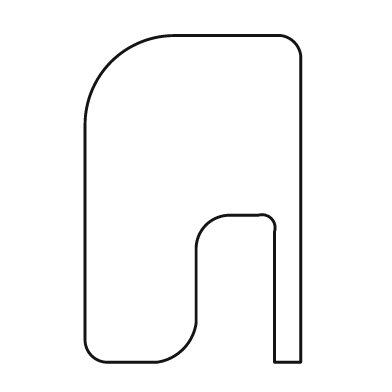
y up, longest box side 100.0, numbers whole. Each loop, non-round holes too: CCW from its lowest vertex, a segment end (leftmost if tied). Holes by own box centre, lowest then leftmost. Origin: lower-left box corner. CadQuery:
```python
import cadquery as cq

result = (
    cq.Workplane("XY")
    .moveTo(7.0, 0.0)
    .lineTo(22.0, 0.0)
    .threePointArc((30.0, 4.0), (34.0, 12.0))
    .lineTo(34.0, 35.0)
    .threePointArc((37.0, 42.0), (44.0, 45.0))
    .lineTo(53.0, 45.0)
    .threePointArc((57.0, 44.0), (58.0, 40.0))
    .lineTo(58.0, 0.0)
    .lineTo(66.0, 0.0)
    .lineTo(66.0, 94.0)
    .threePointArc((64.0, 98.0), (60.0, 100.0))
    .lineTo(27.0, 100.0)
    .threePointArc((8.0, 92.0), (0.0, 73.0))
    .lineTo(0.0, 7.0)
    .threePointArc((2.0, 2.0), (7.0, 0.0))
    .close()
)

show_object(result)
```